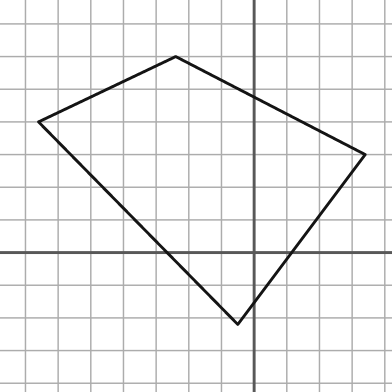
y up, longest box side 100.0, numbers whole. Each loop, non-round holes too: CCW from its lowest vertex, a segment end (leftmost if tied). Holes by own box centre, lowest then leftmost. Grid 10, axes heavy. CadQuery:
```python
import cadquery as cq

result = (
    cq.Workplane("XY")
    .moveTo(-5.0, -22.0)
    .lineTo(34.0, 30.0)
    .lineTo(-24.0, 60.0)
    .lineTo(-66.0, 40.0)
    .close()
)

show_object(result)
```